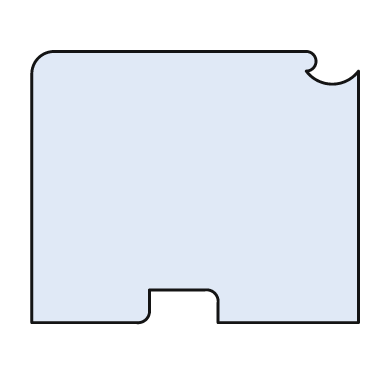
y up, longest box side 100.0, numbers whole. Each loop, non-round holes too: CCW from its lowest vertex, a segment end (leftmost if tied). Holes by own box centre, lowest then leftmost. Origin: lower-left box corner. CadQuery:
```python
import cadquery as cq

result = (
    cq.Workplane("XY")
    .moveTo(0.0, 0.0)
    .lineTo(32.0, 0.0)
    .threePointArc((35.0, 1.0), (36.0, 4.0))
    .lineTo(36.0, 10.0)
    .lineTo(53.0, 10.0)
    .threePointArc((56.0, 9.0), (57.0, 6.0))
    .lineTo(57.0, 0.0)
    .lineTo(100.0, 0.0)
    .lineTo(100.0, 77.0)
    .threePointArc((92.0, 73.0), (84.0, 77.0))
    .threePointArc((87.0, 80.0), (84.0, 83.0))
    .lineTo(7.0, 83.0)
    .threePointArc((2.0, 81.0), (0.0, 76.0))
    .close()
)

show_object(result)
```